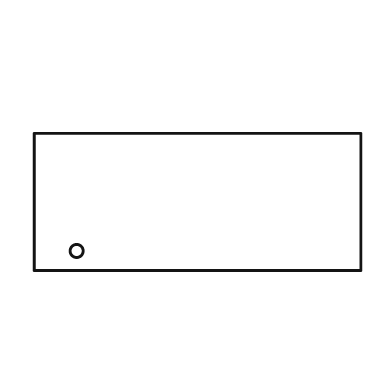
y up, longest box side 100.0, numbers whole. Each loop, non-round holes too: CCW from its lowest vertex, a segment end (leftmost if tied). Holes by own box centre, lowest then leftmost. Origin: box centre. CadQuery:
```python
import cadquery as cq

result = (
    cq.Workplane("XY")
    .moveTo(-50.0, -21.0)
    .lineTo(50.0, -21.0)
    .lineTo(50.0, 21.0)
    .lineTo(-50.0, 21.0)
    .close()
    .moveTo(-37.0, -15.0)
    .circle(2.0)
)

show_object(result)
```